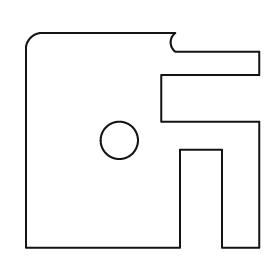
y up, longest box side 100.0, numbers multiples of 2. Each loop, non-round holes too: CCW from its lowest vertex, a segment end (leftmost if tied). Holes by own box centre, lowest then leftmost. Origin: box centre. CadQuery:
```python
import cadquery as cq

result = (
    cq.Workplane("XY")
    .moveTo(-50.0, -46.0)
    .lineTo(16.0, -46.0)
    .lineTo(16.0, -4.0)
    .lineTo(34.0, -4.0)
    .lineTo(34.0, -46.0)
    .lineTo(50.0, -46.0)
    .lineTo(50.0, 8.0)
    .lineTo(8.0, 8.0)
    .lineTo(8.0, 28.0)
    .lineTo(50.0, 28.0)
    .lineTo(50.0, 38.0)
    .lineTo(14.0, 38.0)
    .threePointArc((12.0, 42.0), (14.0, 46.0))
    .lineTo(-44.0, 46.0)
    .threePointArc((-48.0, 44.0), (-50.0, 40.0))
    .close()
    .moveTo(-10.0, 0.0)
    .circle(8.0)
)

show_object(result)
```